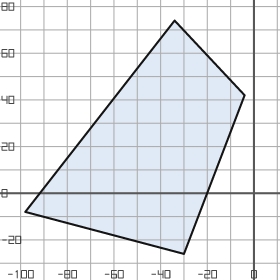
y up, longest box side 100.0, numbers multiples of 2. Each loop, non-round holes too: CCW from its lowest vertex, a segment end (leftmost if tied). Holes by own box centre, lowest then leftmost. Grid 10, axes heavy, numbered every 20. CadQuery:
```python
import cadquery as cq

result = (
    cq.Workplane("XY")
    .moveTo(-30.0, -26.0)
    .lineTo(-4.0, 42.0)
    .lineTo(-34.0, 74.0)
    .lineTo(-98.0, -8.0)
    .close()
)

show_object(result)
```